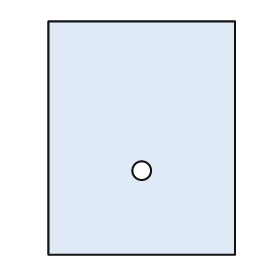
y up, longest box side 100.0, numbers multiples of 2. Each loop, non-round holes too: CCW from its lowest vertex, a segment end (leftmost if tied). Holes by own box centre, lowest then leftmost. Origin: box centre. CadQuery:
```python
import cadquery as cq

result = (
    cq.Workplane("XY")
    .moveTo(-40.0, -50.0)
    .lineTo(40.0, -50.0)
    .lineTo(40.0, 50.0)
    .lineTo(-40.0, 50.0)
    .close()
    .moveTo(0.0, -14.0)
    .circle(4.0)
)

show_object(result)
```